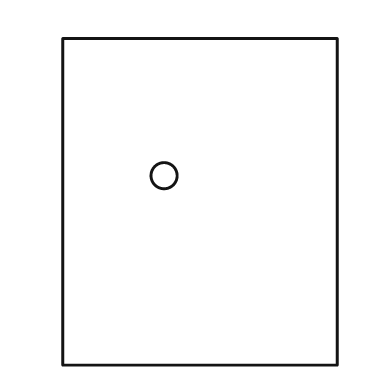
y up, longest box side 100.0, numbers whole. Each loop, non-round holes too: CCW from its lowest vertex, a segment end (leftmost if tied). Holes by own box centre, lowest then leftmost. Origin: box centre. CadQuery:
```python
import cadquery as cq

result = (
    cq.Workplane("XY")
    .moveTo(-42.0, -50.0)
    .lineTo(42.0, -50.0)
    .lineTo(42.0, 50.0)
    .lineTo(-42.0, 50.0)
    .close()
    .moveTo(-11.0, 8.0)
    .circle(4.0)
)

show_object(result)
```